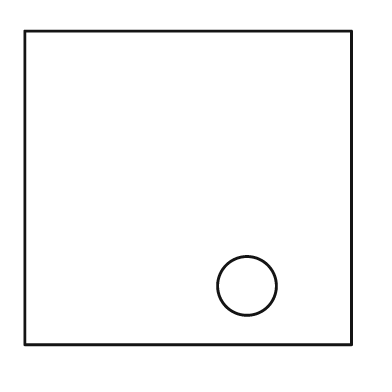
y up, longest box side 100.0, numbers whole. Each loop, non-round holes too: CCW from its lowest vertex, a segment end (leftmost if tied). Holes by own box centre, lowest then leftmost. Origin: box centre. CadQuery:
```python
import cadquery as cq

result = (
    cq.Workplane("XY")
    .moveTo(-50.0, -48.0)
    .lineTo(50.0, -48.0)
    .lineTo(50.0, 48.0)
    .lineTo(-50.0, 48.0)
    .close()
    .moveTo(18.0, -30.0)
    .circle(9.0)
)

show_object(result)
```